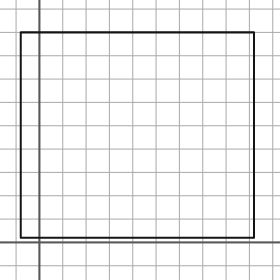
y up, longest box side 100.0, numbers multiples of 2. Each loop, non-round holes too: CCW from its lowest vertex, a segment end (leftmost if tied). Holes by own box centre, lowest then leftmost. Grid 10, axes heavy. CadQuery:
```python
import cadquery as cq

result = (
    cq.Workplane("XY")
    .moveTo(-8.0, 2.0)
    .lineTo(92.0, 2.0)
    .lineTo(92.0, 90.0)
    .lineTo(-8.0, 90.0)
    .close()
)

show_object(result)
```